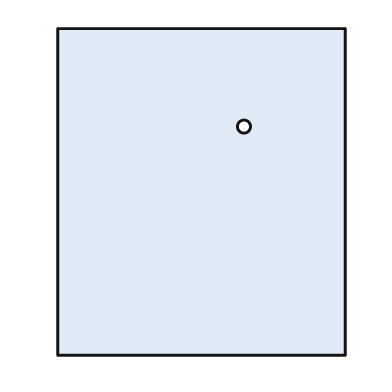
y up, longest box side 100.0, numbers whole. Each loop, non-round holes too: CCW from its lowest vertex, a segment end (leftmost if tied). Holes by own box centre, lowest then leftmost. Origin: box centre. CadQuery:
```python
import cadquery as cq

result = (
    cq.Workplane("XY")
    .moveTo(-44.0, -50.0)
    .lineTo(44.0, -50.0)
    .lineTo(44.0, 50.0)
    .lineTo(-44.0, 50.0)
    .close()
    .moveTo(13.0, 20.0)
    .circle(2.0)
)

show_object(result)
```